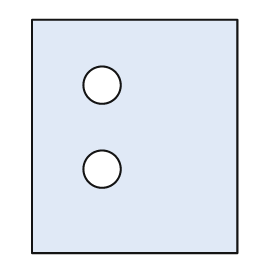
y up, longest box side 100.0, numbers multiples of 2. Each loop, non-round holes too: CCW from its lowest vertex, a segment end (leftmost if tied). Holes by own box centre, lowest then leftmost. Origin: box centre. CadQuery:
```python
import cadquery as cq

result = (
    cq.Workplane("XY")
    .moveTo(-44.0, -50.0)
    .lineTo(44.0, -50.0)
    .lineTo(44.0, 50.0)
    .lineTo(-44.0, 50.0)
    .close()
    .moveTo(-14.0, -14.0)
    .circle(8.0)
    .moveTo(-14.0, 22.0)
    .circle(8.0)
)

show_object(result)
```